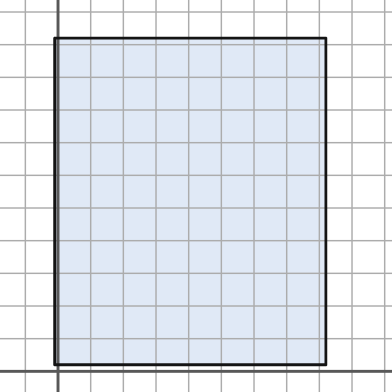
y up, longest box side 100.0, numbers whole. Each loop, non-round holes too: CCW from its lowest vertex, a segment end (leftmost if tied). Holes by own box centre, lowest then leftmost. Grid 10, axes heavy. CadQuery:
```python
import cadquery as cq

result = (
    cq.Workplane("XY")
    .moveTo(-1.0, 2.0)
    .lineTo(82.0, 2.0)
    .lineTo(82.0, 102.0)
    .lineTo(-1.0, 102.0)
    .close()
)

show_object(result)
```